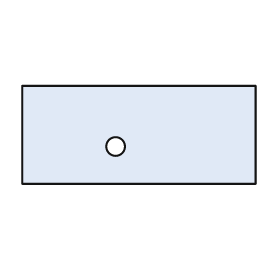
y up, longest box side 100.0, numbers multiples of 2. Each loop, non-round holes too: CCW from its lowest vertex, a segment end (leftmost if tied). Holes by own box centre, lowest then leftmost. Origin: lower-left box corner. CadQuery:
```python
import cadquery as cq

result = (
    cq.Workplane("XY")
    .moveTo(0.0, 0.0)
    .lineTo(100.0, 0.0)
    .lineTo(100.0, 42.0)
    .lineTo(0.0, 42.0)
    .close()
    .moveTo(40.0, 16.0)
    .circle(4.0)
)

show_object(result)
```